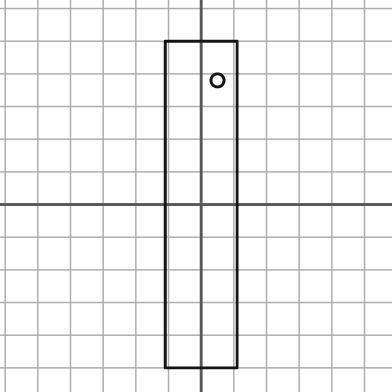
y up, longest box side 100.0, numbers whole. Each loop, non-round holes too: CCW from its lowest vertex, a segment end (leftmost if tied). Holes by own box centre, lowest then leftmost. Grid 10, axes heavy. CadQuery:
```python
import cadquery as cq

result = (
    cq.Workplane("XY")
    .moveTo(-11.0, -50.0)
    .lineTo(11.0, -50.0)
    .lineTo(11.0, 50.0)
    .lineTo(-11.0, 50.0)
    .close()
    .moveTo(5.0, 38.0)
    .circle(2.0)
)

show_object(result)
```